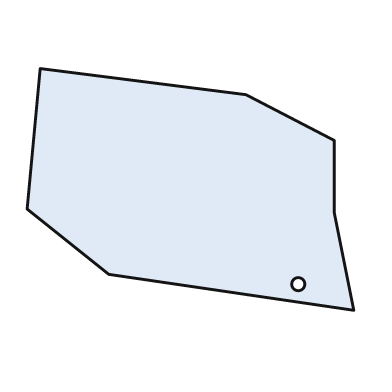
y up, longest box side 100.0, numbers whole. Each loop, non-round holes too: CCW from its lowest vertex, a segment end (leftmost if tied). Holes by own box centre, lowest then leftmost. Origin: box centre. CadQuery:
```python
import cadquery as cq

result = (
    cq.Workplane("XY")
    .moveTo(50.0, -37.0)
    .lineTo(44.0, -7.0)
    .lineTo(44.0, 15.0)
    .lineTo(17.0, 29.0)
    .lineTo(-46.0, 37.0)
    .lineTo(-50.0, -6.0)
    .lineTo(-25.0, -26.0)
    .close()
    .moveTo(33.0, -29.0)
    .circle(2.0)
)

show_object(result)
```